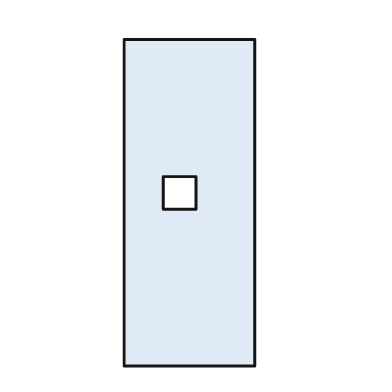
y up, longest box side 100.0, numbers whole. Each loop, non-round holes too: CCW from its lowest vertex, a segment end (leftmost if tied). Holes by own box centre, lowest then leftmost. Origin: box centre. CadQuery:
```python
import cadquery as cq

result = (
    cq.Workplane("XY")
    .moveTo(-20.0, -50.0)
    .lineTo(20.0, -50.0)
    .lineTo(20.0, 50.0)
    .lineTo(-20.0, 50.0)
    .close()
    .moveTo(-8.0, -2.0)
    .lineTo(2.0, -2.0)
    .lineTo(2.0, 8.0)
    .lineTo(-8.0, 8.0)
    .close()
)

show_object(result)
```